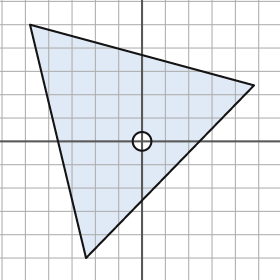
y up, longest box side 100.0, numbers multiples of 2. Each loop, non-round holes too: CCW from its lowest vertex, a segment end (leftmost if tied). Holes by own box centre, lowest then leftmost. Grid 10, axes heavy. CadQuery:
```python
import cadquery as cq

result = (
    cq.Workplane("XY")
    .moveTo(-24.0, -50.0)
    .lineTo(48.0, 24.0)
    .lineTo(-48.0, 50.0)
    .close()
    .moveTo(0.0, 0.0)
    .circle(4.0)
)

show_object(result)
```